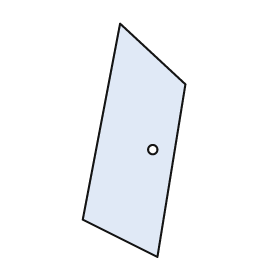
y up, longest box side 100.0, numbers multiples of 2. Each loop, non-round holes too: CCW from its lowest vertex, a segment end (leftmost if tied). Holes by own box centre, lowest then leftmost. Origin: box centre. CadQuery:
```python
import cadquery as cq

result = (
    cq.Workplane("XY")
    .moveTo(10.0, -50.0)
    .lineTo(22.0, 24.0)
    .lineTo(-6.0, 50.0)
    .lineTo(-22.0, -34.0)
    .close()
    .moveTo(8.0, -4.0)
    .circle(2.0)
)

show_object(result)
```